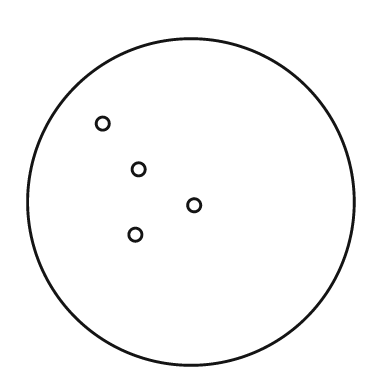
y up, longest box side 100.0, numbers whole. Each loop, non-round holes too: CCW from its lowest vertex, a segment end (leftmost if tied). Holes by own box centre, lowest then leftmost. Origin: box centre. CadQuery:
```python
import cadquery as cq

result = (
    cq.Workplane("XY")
    .moveTo(0.0, 0.0)
    .circle(50.0)
    .moveTo(-17.0, -10.0)
    .circle(2.0)
    .moveTo(1.0, -1.0)
    .circle(2.0)
    .moveTo(-16.0, 10.0)
    .circle(2.0)
    .moveTo(-27.0, 24.0)
    .circle(2.0)
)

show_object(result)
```